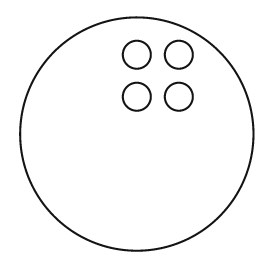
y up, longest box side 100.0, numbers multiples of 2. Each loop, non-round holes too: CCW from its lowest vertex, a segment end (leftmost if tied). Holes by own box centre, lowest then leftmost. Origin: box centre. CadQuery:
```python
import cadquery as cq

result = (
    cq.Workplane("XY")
    .moveTo(0.0, 0.0)
    .circle(50.0)
    .moveTo(0.0, 16.0)
    .circle(6.0)
    .moveTo(18.0, 16.0)
    .circle(6.0)
    .moveTo(0.0, 34.0)
    .circle(6.0)
    .moveTo(18.0, 34.0)
    .circle(6.0)
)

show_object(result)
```